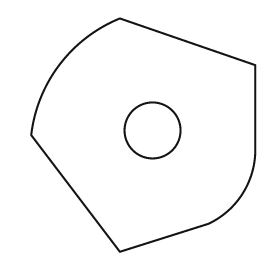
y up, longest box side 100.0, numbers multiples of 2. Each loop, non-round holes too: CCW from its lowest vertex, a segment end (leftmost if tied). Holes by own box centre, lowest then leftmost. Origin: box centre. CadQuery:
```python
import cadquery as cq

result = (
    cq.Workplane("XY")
    .moveTo(-10.0, -50.0)
    .lineTo(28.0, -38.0)
    .threePointArc((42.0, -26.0), (48.0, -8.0))
    .lineTo(48.0, 30.0)
    .lineTo(-10.0, 50.0)
    .threePointArc((-36.0, 30.0), (-48.0, 0.0))
    .close()
    .moveTo(4.0, 2.0)
    .circle(12.0)
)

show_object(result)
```